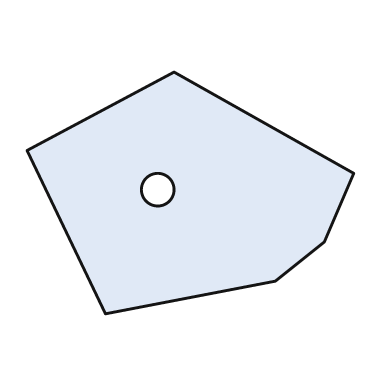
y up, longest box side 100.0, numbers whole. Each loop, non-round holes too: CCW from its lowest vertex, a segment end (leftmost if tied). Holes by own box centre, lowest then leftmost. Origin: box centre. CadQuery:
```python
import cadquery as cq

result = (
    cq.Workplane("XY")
    .moveTo(-26.0, -37.0)
    .lineTo(26.0, -27.0)
    .lineTo(41.0, -15.0)
    .lineTo(50.0, 6.0)
    .lineTo(-5.0, 37.0)
    .lineTo(-50.0, 13.0)
    .close()
    .moveTo(-10.0, 1.0)
    .circle(5.0)
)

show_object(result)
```